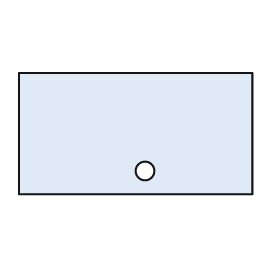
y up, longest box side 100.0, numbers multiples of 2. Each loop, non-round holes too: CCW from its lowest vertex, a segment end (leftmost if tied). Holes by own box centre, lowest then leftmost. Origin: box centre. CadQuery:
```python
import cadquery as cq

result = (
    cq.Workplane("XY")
    .moveTo(-50.0, -26.0)
    .lineTo(50.0, -26.0)
    .lineTo(50.0, 26.0)
    .lineTo(-50.0, 26.0)
    .close()
    .moveTo(4.0, -16.0)
    .circle(4.0)
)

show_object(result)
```